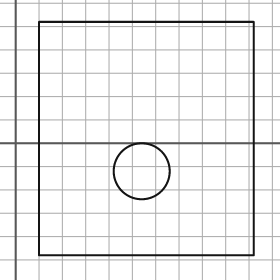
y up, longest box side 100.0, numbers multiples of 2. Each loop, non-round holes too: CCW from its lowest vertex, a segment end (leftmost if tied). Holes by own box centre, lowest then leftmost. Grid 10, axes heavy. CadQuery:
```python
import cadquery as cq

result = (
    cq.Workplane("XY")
    .moveTo(10.0, -48.0)
    .lineTo(102.0, -48.0)
    .lineTo(102.0, 52.0)
    .lineTo(10.0, 52.0)
    .close()
    .moveTo(54.0, -12.0)
    .circle(12.0)
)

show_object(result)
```